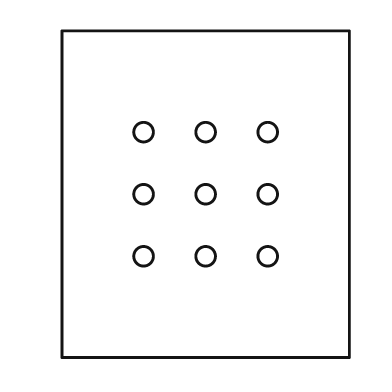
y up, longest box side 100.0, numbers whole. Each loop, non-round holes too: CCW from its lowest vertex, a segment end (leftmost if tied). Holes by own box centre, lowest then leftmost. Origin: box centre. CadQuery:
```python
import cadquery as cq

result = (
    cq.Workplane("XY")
    .moveTo(-44.0, -50.0)
    .lineTo(44.0, -50.0)
    .lineTo(44.0, 50.0)
    .lineTo(-44.0, 50.0)
    .close()
    .moveTo(-19.0, -19.0)
    .circle(3.0)
    .moveTo(0.0, -19.0)
    .circle(3.0)
    .moveTo(19.0, -19.0)
    .circle(3.0)
    .moveTo(-19.0, 0.0)
    .circle(3.0)
    .moveTo(0.0, 0.0)
    .circle(3.0)
    .moveTo(19.0, 0.0)
    .circle(3.0)
    .moveTo(-19.0, 19.0)
    .circle(3.0)
    .moveTo(0.0, 19.0)
    .circle(3.0)
    .moveTo(19.0, 19.0)
    .circle(3.0)
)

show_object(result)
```